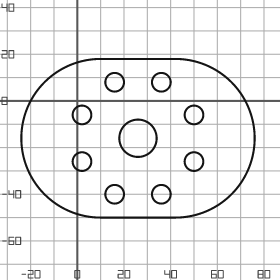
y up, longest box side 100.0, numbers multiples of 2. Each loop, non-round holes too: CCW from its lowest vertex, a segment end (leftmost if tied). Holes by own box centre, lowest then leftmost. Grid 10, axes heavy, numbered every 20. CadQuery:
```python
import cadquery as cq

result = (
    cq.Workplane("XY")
    .moveTo(10.0, -50.0)
    .lineTo(42.0, -50.0)
    .threePointArc((76.0, -16.0), (42.0, 18.0))
    .lineTo(10.0, 18.0)
    .threePointArc((-24.0, -16.0), (10.0, -50.0))
    .close()
    .moveTo(16.0, -40.0)
    .circle(4.0)
    .moveTo(36.0, -40.0)
    .circle(4.0)
    .moveTo(2.0, -26.0)
    .circle(4.0)
    .moveTo(50.0, -26.0)
    .circle(4.0)
    .moveTo(26.0, -16.0)
    .circle(8.0)
    .moveTo(2.0, -6.0)
    .circle(4.0)
    .moveTo(50.0, -6.0)
    .circle(4.0)
    .moveTo(16.0, 8.0)
    .circle(4.0)
    .moveTo(36.0, 8.0)
    .circle(4.0)
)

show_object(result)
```